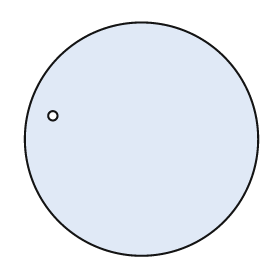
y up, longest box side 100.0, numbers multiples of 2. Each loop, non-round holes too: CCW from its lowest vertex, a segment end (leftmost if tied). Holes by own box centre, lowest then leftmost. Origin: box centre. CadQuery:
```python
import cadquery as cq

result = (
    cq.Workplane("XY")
    .moveTo(0.0, 0.0)
    .circle(50.0)
    .moveTo(-38.0, 10.0)
    .circle(2.0)
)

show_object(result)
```